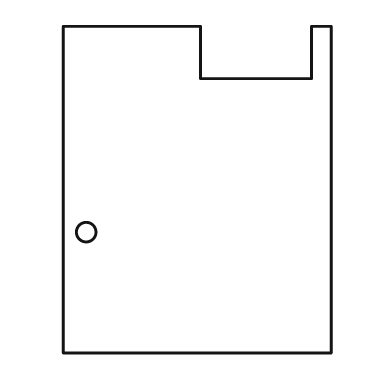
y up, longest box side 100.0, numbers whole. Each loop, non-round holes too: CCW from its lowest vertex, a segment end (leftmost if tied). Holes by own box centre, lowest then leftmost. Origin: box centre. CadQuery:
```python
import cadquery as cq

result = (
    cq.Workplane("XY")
    .moveTo(-41.0, -50.0)
    .lineTo(41.0, -50.0)
    .lineTo(41.0, 50.0)
    .lineTo(35.0, 50.0)
    .lineTo(35.0, 34.0)
    .lineTo(1.0, 34.0)
    .lineTo(1.0, 50.0)
    .lineTo(-41.0, 50.0)
    .close()
    .moveTo(-34.0, -13.0)
    .circle(3.0)
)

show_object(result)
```